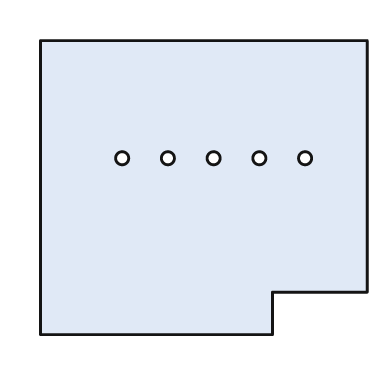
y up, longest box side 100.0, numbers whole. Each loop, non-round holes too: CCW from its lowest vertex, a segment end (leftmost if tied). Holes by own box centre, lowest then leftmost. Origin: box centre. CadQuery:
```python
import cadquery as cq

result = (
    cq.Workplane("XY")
    .moveTo(-50.0, -45.0)
    .lineTo(21.0, -45.0)
    .lineTo(21.0, -32.0)
    .lineTo(50.0, -32.0)
    .lineTo(50.0, 45.0)
    .lineTo(-50.0, 45.0)
    .close()
    .moveTo(-25.0, 9.0)
    .circle(2.0)
    .moveTo(-11.0, 9.0)
    .circle(2.0)
    .moveTo(3.0, 9.0)
    .circle(2.0)
    .moveTo(17.0, 9.0)
    .circle(2.0)
    .moveTo(31.0, 9.0)
    .circle(2.0)
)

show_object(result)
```